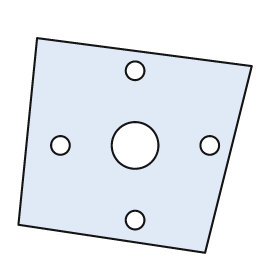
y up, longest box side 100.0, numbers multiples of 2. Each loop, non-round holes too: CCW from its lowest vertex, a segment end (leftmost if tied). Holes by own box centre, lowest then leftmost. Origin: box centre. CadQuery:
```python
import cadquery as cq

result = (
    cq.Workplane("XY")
    .moveTo(30.0, -46.0)
    .lineTo(50.0, 34.0)
    .lineTo(-42.0, 46.0)
    .lineTo(-50.0, -34.0)
    .close()
    .moveTo(0.0, -32.0)
    .circle(4.0)
    .moveTo(-32.0, 0.0)
    .circle(4.0)
    .moveTo(0.0, 0.0)
    .circle(10.0)
    .moveTo(32.0, 0.0)
    .circle(4.0)
    .moveTo(0.0, 32.0)
    .circle(4.0)
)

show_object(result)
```